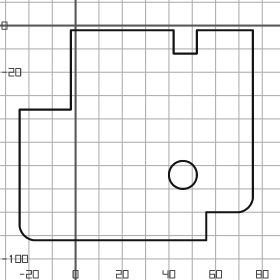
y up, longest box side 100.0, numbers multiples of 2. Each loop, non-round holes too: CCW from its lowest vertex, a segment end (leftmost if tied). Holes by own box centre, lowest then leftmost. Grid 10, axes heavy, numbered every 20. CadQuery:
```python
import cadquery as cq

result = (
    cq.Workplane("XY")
    .moveTo(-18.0, -92.0)
    .lineTo(56.0, -92.0)
    .lineTo(56.0, -80.0)
    .lineTo(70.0, -80.0)
    .threePointArc((74.0, -78.0), (76.0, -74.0))
    .lineTo(76.0, -2.0)
    .lineTo(52.0, -2.0)
    .lineTo(52.0, -12.0)
    .lineTo(42.0, -12.0)
    .lineTo(42.0, -2.0)
    .lineTo(-2.0, -2.0)
    .lineTo(-2.0, -36.0)
    .lineTo(-24.0, -36.0)
    .lineTo(-24.0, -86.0)
    .threePointArc((-22.0, -90.0), (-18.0, -92.0))
    .close()
    .moveTo(46.0, -64.0)
    .circle(6.0)
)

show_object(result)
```